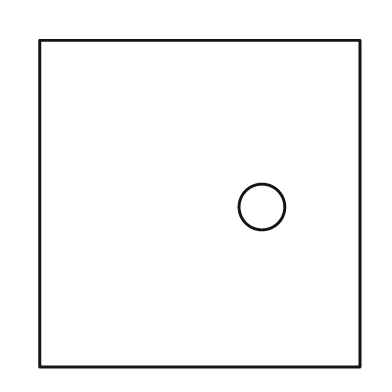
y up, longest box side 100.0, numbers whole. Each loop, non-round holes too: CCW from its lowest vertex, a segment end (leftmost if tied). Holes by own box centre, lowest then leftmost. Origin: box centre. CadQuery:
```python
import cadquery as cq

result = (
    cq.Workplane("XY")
    .moveTo(-49.0, -50.0)
    .lineTo(49.0, -50.0)
    .lineTo(49.0, 50.0)
    .lineTo(-49.0, 50.0)
    .close()
    .moveTo(19.0, -1.0)
    .circle(7.0)
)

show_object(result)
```